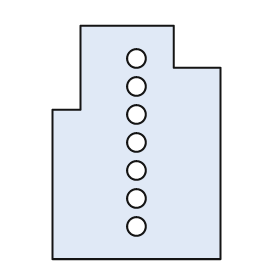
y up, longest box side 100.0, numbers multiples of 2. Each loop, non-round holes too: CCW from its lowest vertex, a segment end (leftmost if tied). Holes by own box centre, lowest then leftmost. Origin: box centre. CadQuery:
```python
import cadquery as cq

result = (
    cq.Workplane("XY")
    .moveTo(-36.0, -50.0)
    .lineTo(36.0, -50.0)
    .lineTo(36.0, 32.0)
    .lineTo(16.0, 32.0)
    .lineTo(16.0, 50.0)
    .lineTo(-24.0, 50.0)
    .lineTo(-24.0, 14.0)
    .lineTo(-36.0, 14.0)
    .close()
    .moveTo(0.0, -36.0)
    .circle(4.0)
    .moveTo(0.0, -24.0)
    .circle(4.0)
    .moveTo(0.0, -12.0)
    .circle(4.0)
    .moveTo(0.0, 0.0)
    .circle(4.0)
    .moveTo(0.0, 12.0)
    .circle(4.0)
    .moveTo(0.0, 24.0)
    .circle(4.0)
    .moveTo(0.0, 36.0)
    .circle(4.0)
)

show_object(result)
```